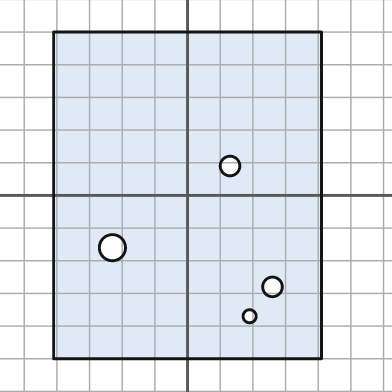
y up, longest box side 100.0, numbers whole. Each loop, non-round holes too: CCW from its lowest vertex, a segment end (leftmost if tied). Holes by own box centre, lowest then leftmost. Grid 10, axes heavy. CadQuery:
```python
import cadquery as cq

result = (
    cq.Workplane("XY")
    .moveTo(-41.0, -50.0)
    .lineTo(41.0, -50.0)
    .lineTo(41.0, 50.0)
    .lineTo(-41.0, 50.0)
    .close()
    .moveTo(19.0, -37.0)
    .circle(2.0)
    .moveTo(26.0, -28.0)
    .circle(3.0)
    .moveTo(-23.0, -16.0)
    .circle(4.0)
    .moveTo(13.0, 9.0)
    .circle(3.0)
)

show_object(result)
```